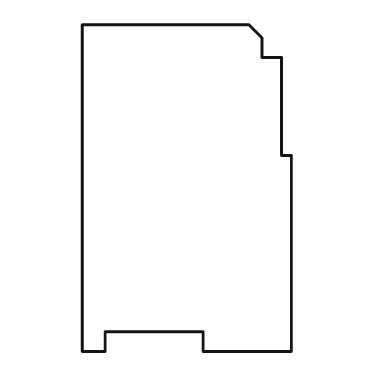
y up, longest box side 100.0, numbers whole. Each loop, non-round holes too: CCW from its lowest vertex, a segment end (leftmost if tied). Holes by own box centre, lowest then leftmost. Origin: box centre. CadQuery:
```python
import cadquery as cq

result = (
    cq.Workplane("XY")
    .moveTo(-32.0, -50.0)
    .lineTo(-25.0, -50.0)
    .lineTo(-25.0, -44.0)
    .lineTo(5.0, -44.0)
    .lineTo(5.0, -50.0)
    .lineTo(32.0, -50.0)
    .lineTo(32.0, 10.0)
    .lineTo(29.0, 10.0)
    .lineTo(29.0, 40.0)
    .lineTo(23.0, 40.0)
    .lineTo(23.0, 46.0)
    .lineTo(19.0, 50.0)
    .lineTo(-32.0, 50.0)
    .close()
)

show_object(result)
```